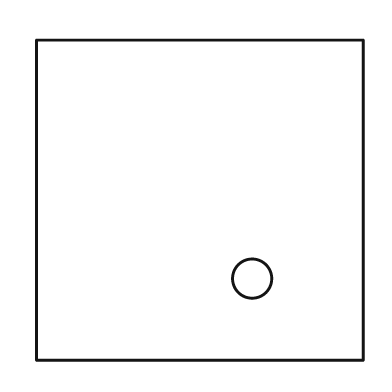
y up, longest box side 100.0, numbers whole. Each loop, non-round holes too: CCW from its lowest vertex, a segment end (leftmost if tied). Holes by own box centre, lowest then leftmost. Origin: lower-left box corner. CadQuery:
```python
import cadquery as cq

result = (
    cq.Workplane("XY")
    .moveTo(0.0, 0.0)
    .lineTo(100.0, 0.0)
    .lineTo(100.0, 98.0)
    .lineTo(0.0, 98.0)
    .close()
    .moveTo(66.0, 25.0)
    .circle(6.0)
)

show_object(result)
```